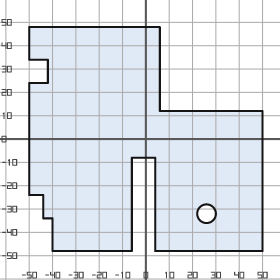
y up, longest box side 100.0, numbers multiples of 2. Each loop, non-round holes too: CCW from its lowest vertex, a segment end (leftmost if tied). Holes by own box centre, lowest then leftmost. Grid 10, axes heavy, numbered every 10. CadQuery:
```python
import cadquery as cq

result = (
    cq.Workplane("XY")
    .moveTo(-40.0, -48.0)
    .lineTo(-6.0, -48.0)
    .lineTo(-6.0, -8.0)
    .lineTo(4.0, -8.0)
    .lineTo(4.0, -48.0)
    .lineTo(50.0, -48.0)
    .lineTo(50.0, 12.0)
    .lineTo(6.0, 12.0)
    .lineTo(6.0, 48.0)
    .lineTo(-50.0, 48.0)
    .lineTo(-50.0, 34.0)
    .lineTo(-42.0, 34.0)
    .lineTo(-42.0, 24.0)
    .lineTo(-50.0, 24.0)
    .lineTo(-50.0, -24.0)
    .lineTo(-44.0, -24.0)
    .lineTo(-44.0, -34.0)
    .lineTo(-40.0, -34.0)
    .close()
    .moveTo(26.0, -32.0)
    .circle(4.0)
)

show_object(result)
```